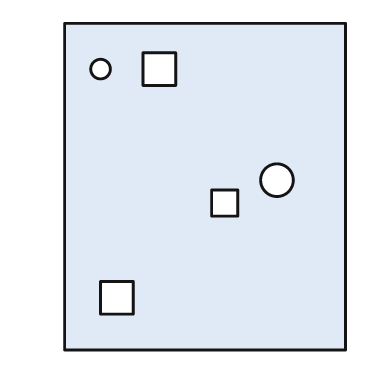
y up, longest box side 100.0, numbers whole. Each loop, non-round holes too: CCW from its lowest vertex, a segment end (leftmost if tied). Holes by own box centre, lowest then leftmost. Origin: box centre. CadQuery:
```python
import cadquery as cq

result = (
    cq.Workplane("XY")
    .moveTo(-43.0, -50.0)
    .lineTo(43.0, -50.0)
    .lineTo(43.0, 50.0)
    .lineTo(-43.0, 50.0)
    .close()
    .moveTo(-32.0, -39.0)
    .lineTo(-22.0, -39.0)
    .lineTo(-22.0, -29.0)
    .lineTo(-32.0, -29.0)
    .close()
    .moveTo(2.0, -9.0)
    .lineTo(10.0, -9.0)
    .lineTo(10.0, -1.0)
    .lineTo(2.0, -1.0)
    .close()
    .moveTo(22.0, 2.0)
    .circle(5.0)
    .moveTo(-32.0, 36.0)
    .circle(3.0)
    .moveTo(-19.0, 31.0)
    .lineTo(-9.0, 31.0)
    .lineTo(-9.0, 41.0)
    .lineTo(-19.0, 41.0)
    .close()
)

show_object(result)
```